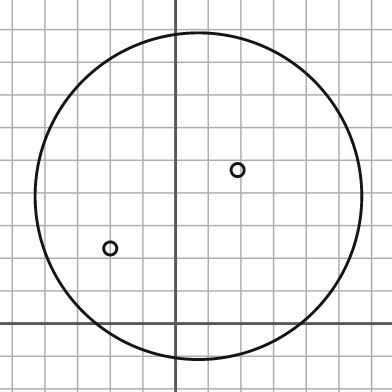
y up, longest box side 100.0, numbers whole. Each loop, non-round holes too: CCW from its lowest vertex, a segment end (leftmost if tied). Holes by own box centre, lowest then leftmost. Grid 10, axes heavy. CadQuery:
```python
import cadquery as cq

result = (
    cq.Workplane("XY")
    .moveTo(7.0, 39.0)
    .circle(50.0)
    .moveTo(-20.0, 23.0)
    .circle(2.0)
    .moveTo(19.0, 47.0)
    .circle(2.0)
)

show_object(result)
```